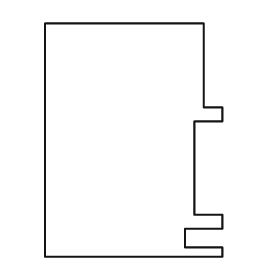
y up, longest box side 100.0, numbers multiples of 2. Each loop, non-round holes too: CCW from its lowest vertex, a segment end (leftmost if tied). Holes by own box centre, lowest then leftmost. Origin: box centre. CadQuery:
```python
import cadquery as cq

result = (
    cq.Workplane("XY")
    .moveTo(-38.0, -50.0)
    .lineTo(38.0, -50.0)
    .lineTo(38.0, -46.0)
    .lineTo(22.0, -46.0)
    .lineTo(22.0, -38.0)
    .lineTo(38.0, -38.0)
    .lineTo(38.0, -32.0)
    .lineTo(26.0, -32.0)
    .lineTo(26.0, 8.0)
    .lineTo(38.0, 8.0)
    .lineTo(38.0, 14.0)
    .lineTo(30.0, 14.0)
    .lineTo(30.0, 50.0)
    .lineTo(-38.0, 50.0)
    .close()
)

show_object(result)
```